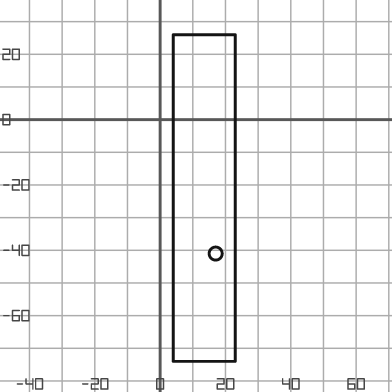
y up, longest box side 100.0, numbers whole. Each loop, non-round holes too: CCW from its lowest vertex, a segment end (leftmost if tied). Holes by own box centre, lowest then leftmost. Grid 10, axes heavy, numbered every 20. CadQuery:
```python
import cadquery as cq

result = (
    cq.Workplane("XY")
    .moveTo(4.0, -74.0)
    .lineTo(23.0, -74.0)
    .lineTo(23.0, 26.0)
    .lineTo(4.0, 26.0)
    .close()
    .moveTo(17.0, -41.0)
    .circle(2.0)
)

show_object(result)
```